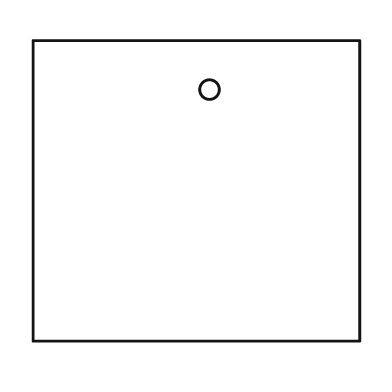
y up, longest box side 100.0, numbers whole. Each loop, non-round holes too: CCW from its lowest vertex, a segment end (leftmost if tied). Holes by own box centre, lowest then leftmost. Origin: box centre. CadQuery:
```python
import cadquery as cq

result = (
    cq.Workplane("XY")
    .moveTo(-50.0, -46.0)
    .lineTo(50.0, -46.0)
    .lineTo(50.0, 46.0)
    .lineTo(-50.0, 46.0)
    .close()
    .moveTo(4.0, 31.0)
    .circle(3.0)
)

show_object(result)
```